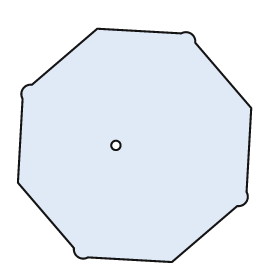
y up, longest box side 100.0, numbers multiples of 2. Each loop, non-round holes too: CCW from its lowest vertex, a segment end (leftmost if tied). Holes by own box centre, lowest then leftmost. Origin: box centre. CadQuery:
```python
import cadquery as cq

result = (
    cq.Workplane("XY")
    .moveTo(16.0, -50.0)
    .lineTo(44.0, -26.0)
    .threePointArc((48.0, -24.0), (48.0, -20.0))
    .lineTo(50.0, 16.0)
    .lineTo(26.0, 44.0)
    .threePointArc((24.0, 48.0), (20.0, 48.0))
    .lineTo(-16.0, 50.0)
    .lineTo(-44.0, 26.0)
    .threePointArc((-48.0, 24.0), (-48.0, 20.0))
    .lineTo(-50.0, -16.0)
    .lineTo(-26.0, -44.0)
    .threePointArc((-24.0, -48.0), (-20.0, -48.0))
    .close()
    .moveTo(-8.0, 0.0)
    .circle(2.0)
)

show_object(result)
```